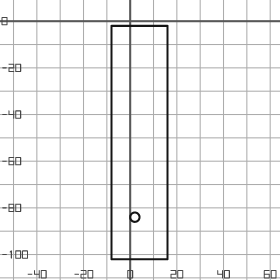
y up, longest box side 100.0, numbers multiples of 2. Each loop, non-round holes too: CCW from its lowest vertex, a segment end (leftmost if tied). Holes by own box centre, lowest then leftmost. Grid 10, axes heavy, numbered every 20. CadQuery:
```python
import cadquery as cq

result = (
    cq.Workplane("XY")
    .moveTo(-8.0, -102.0)
    .lineTo(16.0, -102.0)
    .lineTo(16.0, -2.0)
    .lineTo(-8.0, -2.0)
    .close()
    .moveTo(2.0, -84.0)
    .circle(2.0)
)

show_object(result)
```